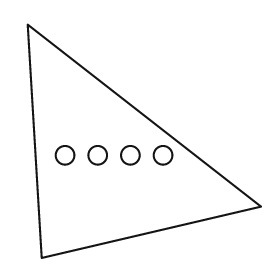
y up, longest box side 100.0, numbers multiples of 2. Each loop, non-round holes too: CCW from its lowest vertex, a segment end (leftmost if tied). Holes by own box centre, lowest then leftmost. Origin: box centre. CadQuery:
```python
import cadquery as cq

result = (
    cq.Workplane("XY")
    .moveTo(-44.0, -50.0)
    .lineTo(50.0, -28.0)
    .lineTo(-50.0, 50.0)
    .close()
    .moveTo(-34.0, -6.0)
    .circle(4.0)
    .moveTo(-20.0, -6.0)
    .circle(4.0)
    .moveTo(-6.0, -6.0)
    .circle(4.0)
    .moveTo(8.0, -6.0)
    .circle(4.0)
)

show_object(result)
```